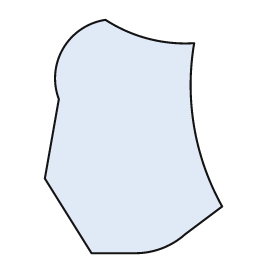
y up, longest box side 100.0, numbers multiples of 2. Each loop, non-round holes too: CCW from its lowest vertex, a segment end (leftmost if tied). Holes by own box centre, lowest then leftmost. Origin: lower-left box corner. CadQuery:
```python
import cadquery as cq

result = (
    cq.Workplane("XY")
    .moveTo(20.0, 0.0)
    .lineTo(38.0, 0.0)
    .threePointArc((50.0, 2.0), (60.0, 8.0))
    .lineTo(76.0, 20.0)
    .threePointArc((64.0, 54.0), (64.0, 90.0))
    .threePointArc((44.0, 92.0), (26.0, 100.0))
    .threePointArc((8.0, 88.0), (6.0, 66.0))
    .lineTo(0.0, 32.0)
    .close()
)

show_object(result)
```